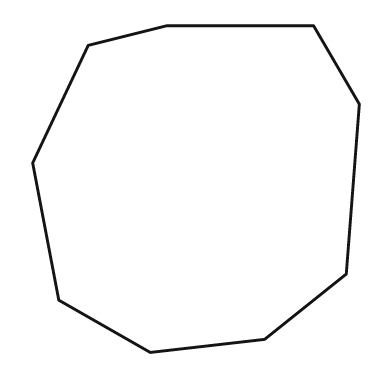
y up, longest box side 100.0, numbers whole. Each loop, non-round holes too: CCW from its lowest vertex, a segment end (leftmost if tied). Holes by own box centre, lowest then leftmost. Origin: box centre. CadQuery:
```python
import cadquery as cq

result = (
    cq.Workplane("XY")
    .moveTo(-14.0, -50.0)
    .lineTo(21.0, -46.0)
    .lineTo(46.0, -26.0)
    .lineTo(50.0, 26.0)
    .lineTo(36.0, 50.0)
    .lineTo(-9.0, 50.0)
    .lineTo(-33.0, 44.0)
    .lineTo(-50.0, 8.0)
    .lineTo(-42.0, -34.0)
    .close()
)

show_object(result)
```